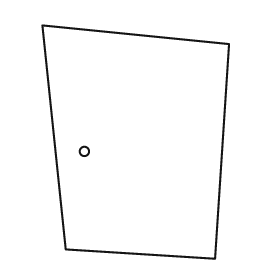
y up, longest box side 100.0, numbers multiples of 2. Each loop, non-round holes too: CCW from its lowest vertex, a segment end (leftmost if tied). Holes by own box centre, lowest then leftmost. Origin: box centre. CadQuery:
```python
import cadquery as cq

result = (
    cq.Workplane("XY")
    .moveTo(34.0, -50.0)
    .lineTo(40.0, 42.0)
    .lineTo(-40.0, 50.0)
    .lineTo(-30.0, -46.0)
    .close()
    .moveTo(-22.0, -4.0)
    .circle(2.0)
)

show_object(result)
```